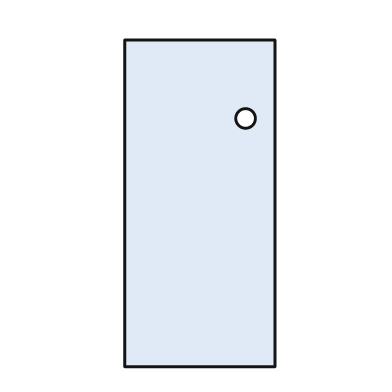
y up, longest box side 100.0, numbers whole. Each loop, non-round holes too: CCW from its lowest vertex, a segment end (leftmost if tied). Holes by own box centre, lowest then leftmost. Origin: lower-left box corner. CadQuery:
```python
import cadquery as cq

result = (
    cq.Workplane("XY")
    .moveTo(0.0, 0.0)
    .lineTo(46.0, 0.0)
    .lineTo(46.0, 100.0)
    .lineTo(0.0, 100.0)
    .close()
    .moveTo(37.0, 76.0)
    .circle(3.0)
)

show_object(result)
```